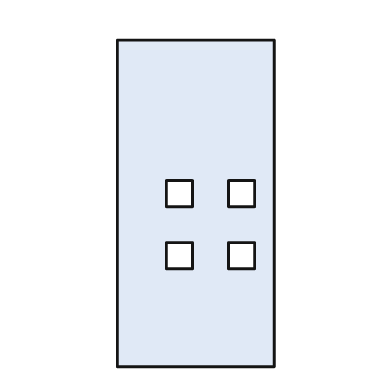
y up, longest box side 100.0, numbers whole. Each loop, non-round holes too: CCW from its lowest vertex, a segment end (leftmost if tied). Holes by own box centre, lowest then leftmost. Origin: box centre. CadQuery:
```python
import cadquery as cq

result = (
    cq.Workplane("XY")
    .moveTo(-24.0, -50.0)
    .lineTo(24.0, -50.0)
    .lineTo(24.0, 50.0)
    .lineTo(-24.0, 50.0)
    .close()
    .moveTo(-9.0, -20.0)
    .lineTo(-1.0, -20.0)
    .lineTo(-1.0, -12.0)
    .lineTo(-9.0, -12.0)
    .close()
    .moveTo(10.0, -20.0)
    .lineTo(18.0, -20.0)
    .lineTo(18.0, -12.0)
    .lineTo(10.0, -12.0)
    .close()
    .moveTo(-9.0, -1.0)
    .lineTo(-1.0, -1.0)
    .lineTo(-1.0, 7.0)
    .lineTo(-9.0, 7.0)
    .close()
    .moveTo(10.0, -1.0)
    .lineTo(18.0, -1.0)
    .lineTo(18.0, 7.0)
    .lineTo(10.0, 7.0)
    .close()
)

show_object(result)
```